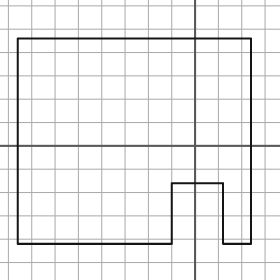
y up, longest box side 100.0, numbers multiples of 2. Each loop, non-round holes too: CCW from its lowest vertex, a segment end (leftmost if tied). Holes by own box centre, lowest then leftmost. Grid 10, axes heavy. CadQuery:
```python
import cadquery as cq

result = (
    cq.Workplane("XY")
    .moveTo(-76.0, -42.0)
    .lineTo(-10.0, -42.0)
    .lineTo(-10.0, -16.0)
    .lineTo(12.0, -16.0)
    .lineTo(12.0, -42.0)
    .lineTo(24.0, -42.0)
    .lineTo(24.0, 46.0)
    .lineTo(-76.0, 46.0)
    .close()
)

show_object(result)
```